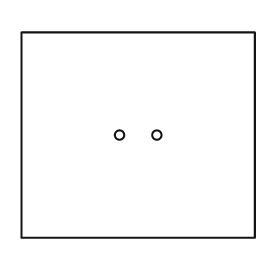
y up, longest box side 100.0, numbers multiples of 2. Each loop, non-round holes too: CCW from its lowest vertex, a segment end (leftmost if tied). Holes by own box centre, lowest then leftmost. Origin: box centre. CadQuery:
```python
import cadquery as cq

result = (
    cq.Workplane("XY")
    .moveTo(-50.0, -44.0)
    .lineTo(50.0, -44.0)
    .lineTo(50.0, 44.0)
    .lineTo(-50.0, 44.0)
    .close()
    .moveTo(-8.0, 0.0)
    .circle(2.0)
    .moveTo(8.0, 0.0)
    .circle(2.0)
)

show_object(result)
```